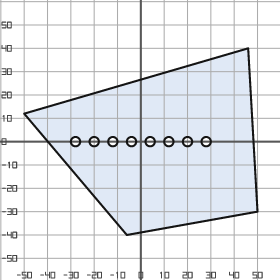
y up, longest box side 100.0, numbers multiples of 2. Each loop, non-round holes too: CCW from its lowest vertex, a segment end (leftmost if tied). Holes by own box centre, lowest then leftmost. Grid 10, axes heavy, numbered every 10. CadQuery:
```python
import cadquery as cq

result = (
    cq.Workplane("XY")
    .moveTo(-6.0, -40.0)
    .lineTo(50.0, -30.0)
    .lineTo(46.0, 40.0)
    .lineTo(-50.0, 12.0)
    .close()
    .moveTo(-28.0, 0.0)
    .circle(2.0)
    .moveTo(-20.0, 0.0)
    .circle(2.0)
    .moveTo(-12.0, 0.0)
    .circle(2.0)
    .moveTo(-4.0, 0.0)
    .circle(2.0)
    .moveTo(4.0, 0.0)
    .circle(2.0)
    .moveTo(12.0, 0.0)
    .circle(2.0)
    .moveTo(20.0, 0.0)
    .circle(2.0)
    .moveTo(28.0, 0.0)
    .circle(2.0)
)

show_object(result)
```